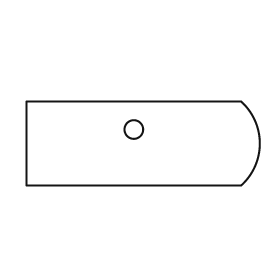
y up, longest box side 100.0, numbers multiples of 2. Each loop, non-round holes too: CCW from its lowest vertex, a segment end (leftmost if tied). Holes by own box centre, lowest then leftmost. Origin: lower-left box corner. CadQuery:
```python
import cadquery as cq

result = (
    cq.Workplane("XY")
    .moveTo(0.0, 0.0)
    .lineTo(92.0, 0.0)
    .threePointArc((100.0, 18.0), (92.0, 36.0))
    .lineTo(0.0, 36.0)
    .close()
    .moveTo(46.0, 24.0)
    .circle(4.0)
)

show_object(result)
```